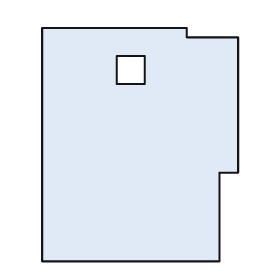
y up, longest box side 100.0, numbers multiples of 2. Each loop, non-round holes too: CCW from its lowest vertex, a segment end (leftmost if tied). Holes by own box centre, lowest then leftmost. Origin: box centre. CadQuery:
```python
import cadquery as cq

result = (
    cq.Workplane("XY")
    .moveTo(-42.0, -50.0)
    .lineTo(34.0, -50.0)
    .lineTo(34.0, -12.0)
    .lineTo(42.0, -12.0)
    .lineTo(42.0, 46.0)
    .lineTo(20.0, 46.0)
    .lineTo(20.0, 50.0)
    .lineTo(-42.0, 50.0)
    .close()
    .moveTo(-10.0, 26.0)
    .lineTo(2.0, 26.0)
    .lineTo(2.0, 38.0)
    .lineTo(-10.0, 38.0)
    .close()
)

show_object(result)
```